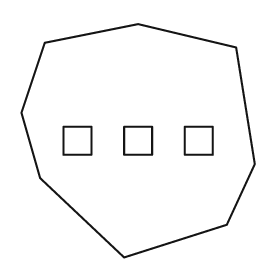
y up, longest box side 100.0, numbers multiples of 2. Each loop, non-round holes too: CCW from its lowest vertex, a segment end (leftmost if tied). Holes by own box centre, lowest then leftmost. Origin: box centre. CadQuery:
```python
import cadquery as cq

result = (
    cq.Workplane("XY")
    .moveTo(-6.0, -50.0)
    .lineTo(38.0, -36.0)
    .lineTo(50.0, -10.0)
    .lineTo(42.0, 40.0)
    .lineTo(0.0, 50.0)
    .lineTo(-40.0, 42.0)
    .lineTo(-50.0, 12.0)
    .lineTo(-42.0, -16.0)
    .close()
    .moveTo(-32.0, -6.0)
    .lineTo(-20.0, -6.0)
    .lineTo(-20.0, 6.0)
    .lineTo(-32.0, 6.0)
    .close()
    .moveTo(-6.0, -6.0)
    .lineTo(6.0, -6.0)
    .lineTo(6.0, 6.0)
    .lineTo(-6.0, 6.0)
    .close()
    .moveTo(20.0, -6.0)
    .lineTo(32.0, -6.0)
    .lineTo(32.0, 6.0)
    .lineTo(20.0, 6.0)
    .close()
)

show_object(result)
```